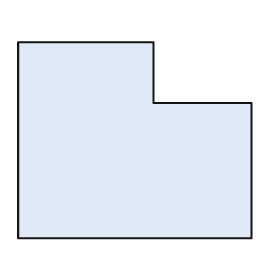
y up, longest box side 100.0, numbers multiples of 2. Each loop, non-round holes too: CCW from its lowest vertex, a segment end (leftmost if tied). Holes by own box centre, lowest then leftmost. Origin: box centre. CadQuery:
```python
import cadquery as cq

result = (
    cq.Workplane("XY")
    .moveTo(-50.0, -42.0)
    .lineTo(50.0, -42.0)
    .lineTo(50.0, 16.0)
    .lineTo(8.0, 16.0)
    .lineTo(8.0, 42.0)
    .lineTo(-50.0, 42.0)
    .close()
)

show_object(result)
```